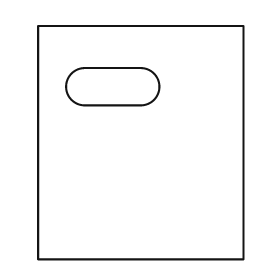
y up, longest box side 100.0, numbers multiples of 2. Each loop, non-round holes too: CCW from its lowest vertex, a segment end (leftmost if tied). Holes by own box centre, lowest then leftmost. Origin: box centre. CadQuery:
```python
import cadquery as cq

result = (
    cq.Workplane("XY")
    .moveTo(-44.0, -50.0)
    .lineTo(44.0, -50.0)
    .lineTo(44.0, 50.0)
    .lineTo(-44.0, 50.0)
    .close()
    .moveTo(-24.0, 16.0)
    .lineTo(0.0, 16.0)
    .threePointArc((8.0, 24.0), (0.0, 32.0))
    .lineTo(-24.0, 32.0)
    .threePointArc((-32.0, 24.0), (-24.0, 16.0))
    .close()
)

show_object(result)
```